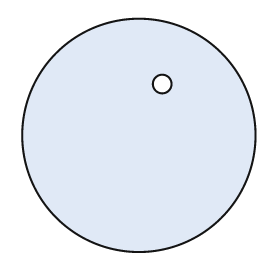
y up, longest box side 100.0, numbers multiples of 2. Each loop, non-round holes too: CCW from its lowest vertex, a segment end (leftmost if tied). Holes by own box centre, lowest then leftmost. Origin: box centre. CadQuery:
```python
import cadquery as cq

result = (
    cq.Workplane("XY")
    .moveTo(0.0, 0.0)
    .circle(50.0)
    .moveTo(10.0, 22.0)
    .circle(4.0)
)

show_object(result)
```